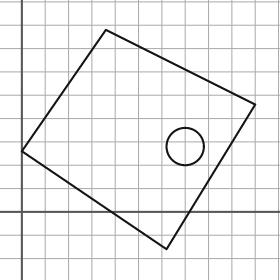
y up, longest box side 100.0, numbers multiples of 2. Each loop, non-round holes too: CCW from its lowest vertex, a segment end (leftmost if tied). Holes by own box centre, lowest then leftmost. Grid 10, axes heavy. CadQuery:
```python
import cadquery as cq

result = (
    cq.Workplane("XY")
    .moveTo(62.0, -16.0)
    .lineTo(100.0, 46.0)
    .lineTo(36.0, 78.0)
    .lineTo(0.0, 26.0)
    .close()
    .moveTo(70.0, 28.0)
    .circle(8.0)
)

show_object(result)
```